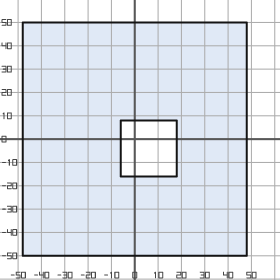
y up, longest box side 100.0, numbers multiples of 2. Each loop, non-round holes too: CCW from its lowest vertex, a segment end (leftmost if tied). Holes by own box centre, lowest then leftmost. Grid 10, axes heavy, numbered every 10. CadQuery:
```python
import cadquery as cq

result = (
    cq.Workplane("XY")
    .moveTo(-48.0, -50.0)
    .lineTo(48.0, -50.0)
    .lineTo(48.0, 50.0)
    .lineTo(-48.0, 50.0)
    .close()
    .moveTo(-6.0, -16.0)
    .lineTo(18.0, -16.0)
    .lineTo(18.0, 8.0)
    .lineTo(-6.0, 8.0)
    .close()
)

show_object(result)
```